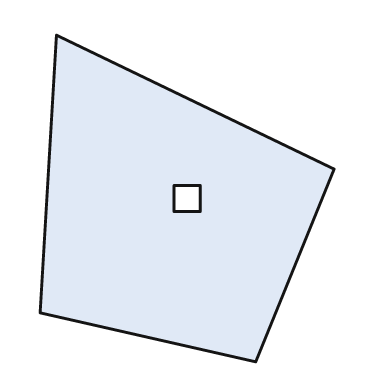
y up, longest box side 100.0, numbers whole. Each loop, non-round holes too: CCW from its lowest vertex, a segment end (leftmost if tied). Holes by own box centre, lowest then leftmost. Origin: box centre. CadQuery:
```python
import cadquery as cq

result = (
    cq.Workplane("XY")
    .moveTo(21.0, -50.0)
    .lineTo(45.0, 9.0)
    .lineTo(-40.0, 50.0)
    .lineTo(-45.0, -35.0)
    .close()
    .moveTo(-4.0, -4.0)
    .lineTo(4.0, -4.0)
    .lineTo(4.0, 4.0)
    .lineTo(-4.0, 4.0)
    .close()
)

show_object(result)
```